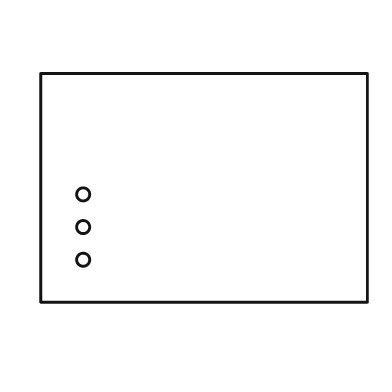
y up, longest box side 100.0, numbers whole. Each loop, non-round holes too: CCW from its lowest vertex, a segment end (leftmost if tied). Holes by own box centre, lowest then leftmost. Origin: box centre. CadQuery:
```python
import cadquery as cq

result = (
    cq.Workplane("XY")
    .moveTo(-50.0, -35.0)
    .lineTo(50.0, -35.0)
    .lineTo(50.0, 35.0)
    .lineTo(-50.0, 35.0)
    .close()
    .moveTo(-37.0, -22.0)
    .circle(2.0)
    .moveTo(-37.0, -12.0)
    .circle(2.0)
    .moveTo(-37.0, -2.0)
    .circle(2.0)
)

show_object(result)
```